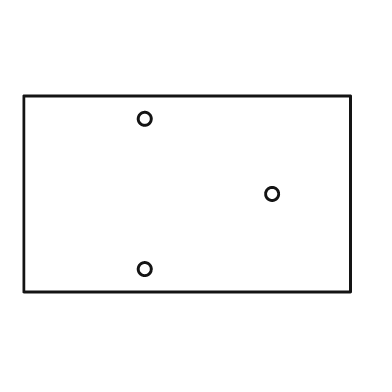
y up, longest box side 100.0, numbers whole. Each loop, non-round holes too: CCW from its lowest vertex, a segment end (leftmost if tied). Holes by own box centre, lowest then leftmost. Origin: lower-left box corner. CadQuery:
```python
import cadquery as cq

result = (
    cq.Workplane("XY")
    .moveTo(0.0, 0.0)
    .lineTo(100.0, 0.0)
    .lineTo(100.0, 60.0)
    .lineTo(0.0, 60.0)
    .close()
    .moveTo(37.0, 7.0)
    .circle(2.0)
    .moveTo(76.0, 30.0)
    .circle(2.0)
    .moveTo(37.0, 53.0)
    .circle(2.0)
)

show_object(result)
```